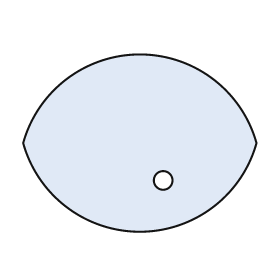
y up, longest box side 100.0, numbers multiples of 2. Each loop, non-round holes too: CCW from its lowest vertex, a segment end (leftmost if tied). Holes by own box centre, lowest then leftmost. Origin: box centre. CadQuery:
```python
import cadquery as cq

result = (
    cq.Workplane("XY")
    .moveTo(-50.0, 0.0)
    .threePointArc((0.0, -38.0), (50.0, 0.0))
    .threePointArc((0.0, 38.0), (-50.0, 0.0))
    .close()
    .moveTo(10.0, -16.0)
    .circle(4.0)
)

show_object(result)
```